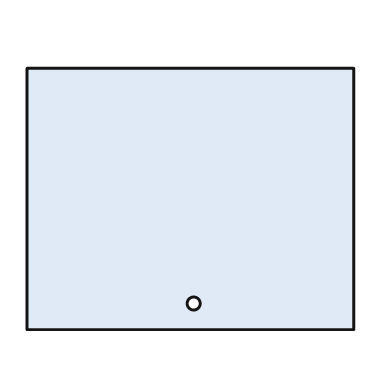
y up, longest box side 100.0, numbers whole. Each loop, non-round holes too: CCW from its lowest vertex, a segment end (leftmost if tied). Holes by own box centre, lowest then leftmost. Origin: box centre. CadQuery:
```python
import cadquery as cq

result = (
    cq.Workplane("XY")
    .moveTo(-50.0, -40.0)
    .lineTo(50.0, -40.0)
    .lineTo(50.0, 40.0)
    .lineTo(-50.0, 40.0)
    .close()
    .moveTo(1.0, -32.0)
    .circle(2.0)
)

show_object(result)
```